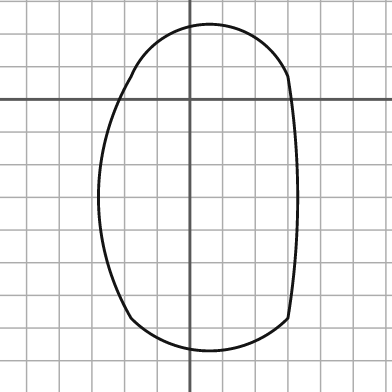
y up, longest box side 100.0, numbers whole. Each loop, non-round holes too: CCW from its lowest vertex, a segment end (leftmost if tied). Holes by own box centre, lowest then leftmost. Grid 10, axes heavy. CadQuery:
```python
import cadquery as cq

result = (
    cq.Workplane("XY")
    .moveTo(-18.0, -67.0)
    .threePointArc((6.0, -77.0), (30.0, -67.0))
    .threePointArc((33.0, -30.0), (30.0, 7.0))
    .threePointArc((6.0, 23.0), (-18.0, 7.0))
    .threePointArc((-28.0, -30.0), (-18.0, -67.0))
    .close()
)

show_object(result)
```